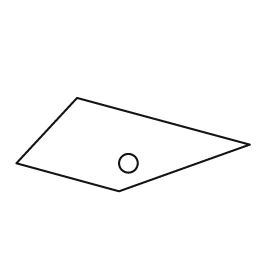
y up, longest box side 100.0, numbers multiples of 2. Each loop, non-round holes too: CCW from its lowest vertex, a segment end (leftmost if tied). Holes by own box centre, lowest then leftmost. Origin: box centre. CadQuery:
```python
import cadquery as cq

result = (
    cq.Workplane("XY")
    .moveTo(-6.0, -20.0)
    .lineTo(50.0, 0.0)
    .lineTo(-24.0, 20.0)
    .lineTo(-50.0, -8.0)
    .close()
    .moveTo(-2.0, -8.0)
    .circle(4.0)
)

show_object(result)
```